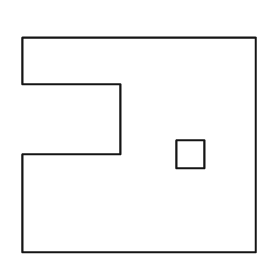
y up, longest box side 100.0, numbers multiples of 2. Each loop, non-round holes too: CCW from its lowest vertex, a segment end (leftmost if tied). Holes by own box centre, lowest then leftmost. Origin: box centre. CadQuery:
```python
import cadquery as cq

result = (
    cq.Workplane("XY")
    .moveTo(-50.0, -46.0)
    .lineTo(50.0, -46.0)
    .lineTo(50.0, 46.0)
    .lineTo(-50.0, 46.0)
    .lineTo(-50.0, 26.0)
    .lineTo(-8.0, 26.0)
    .lineTo(-8.0, -4.0)
    .lineTo(-50.0, -4.0)
    .close()
    .moveTo(16.0, -10.0)
    .lineTo(28.0, -10.0)
    .lineTo(28.0, 2.0)
    .lineTo(16.0, 2.0)
    .close()
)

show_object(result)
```